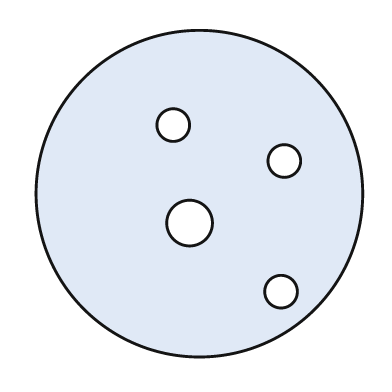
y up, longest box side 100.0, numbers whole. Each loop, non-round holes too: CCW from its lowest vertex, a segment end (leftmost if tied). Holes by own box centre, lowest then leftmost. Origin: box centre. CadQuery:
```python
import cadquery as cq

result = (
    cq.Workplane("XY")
    .moveTo(0.0, 0.0)
    .circle(50.0)
    .moveTo(25.0, -30.0)
    .circle(5.0)
    .moveTo(-3.0, -9.0)
    .circle(7.0)
    .moveTo(26.0, 10.0)
    .circle(5.0)
    .moveTo(-8.0, 21.0)
    .circle(5.0)
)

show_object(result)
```